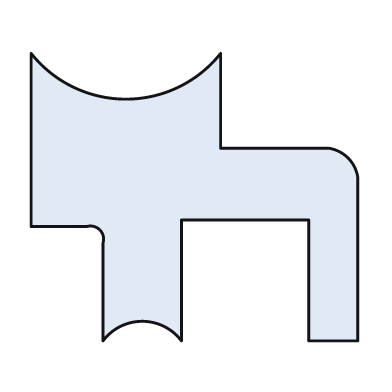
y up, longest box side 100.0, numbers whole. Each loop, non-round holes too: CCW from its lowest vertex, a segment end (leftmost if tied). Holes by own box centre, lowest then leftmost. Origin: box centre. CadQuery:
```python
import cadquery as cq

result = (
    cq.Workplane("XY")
    .moveTo(-28.0, -44.0)
    .threePointArc((-16.0, -38.0), (-4.0, -44.0))
    .lineTo(-4.0, -7.0)
    .lineTo(35.0, -7.0)
    .lineTo(35.0, -44.0)
    .lineTo(50.0, -44.0)
    .lineTo(50.0, 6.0)
    .threePointArc((47.0, 12.0), (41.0, 15.0))
    .lineTo(8.0, 15.0)
    .lineTo(8.0, 44.0)
    .threePointArc((-21.0, 30.0), (-50.0, 44.0))
    .lineTo(-50.0, -9.0)
    .lineTo(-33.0, -9.0)
    .threePointArc((-29.0, -10.0), (-28.0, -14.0))
    .close()
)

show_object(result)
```